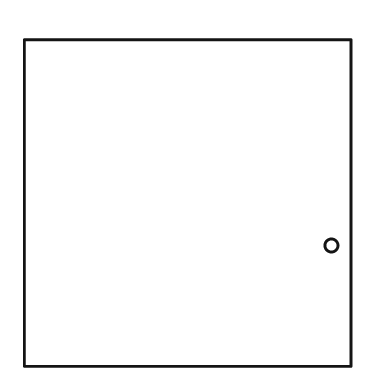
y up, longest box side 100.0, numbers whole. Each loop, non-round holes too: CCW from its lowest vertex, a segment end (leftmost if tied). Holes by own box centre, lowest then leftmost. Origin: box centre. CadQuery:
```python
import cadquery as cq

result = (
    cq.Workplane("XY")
    .moveTo(-50.0, -50.0)
    .lineTo(50.0, -50.0)
    .lineTo(50.0, 50.0)
    .lineTo(-50.0, 50.0)
    .close()
    .moveTo(44.0, -13.0)
    .circle(2.0)
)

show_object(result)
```